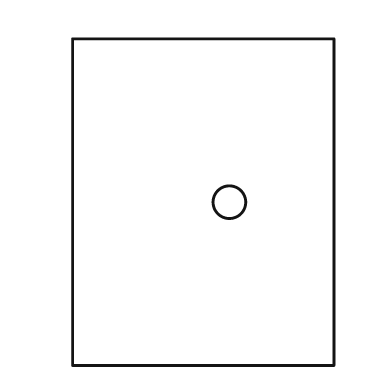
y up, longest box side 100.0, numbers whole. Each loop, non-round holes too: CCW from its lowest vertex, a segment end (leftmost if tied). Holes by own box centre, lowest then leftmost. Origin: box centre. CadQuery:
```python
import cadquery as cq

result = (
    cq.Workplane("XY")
    .moveTo(-40.0, -50.0)
    .lineTo(40.0, -50.0)
    .lineTo(40.0, 50.0)
    .lineTo(-40.0, 50.0)
    .close()
    .moveTo(8.0, 0.0)
    .circle(5.0)
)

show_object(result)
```